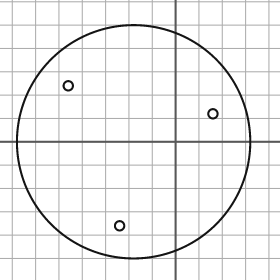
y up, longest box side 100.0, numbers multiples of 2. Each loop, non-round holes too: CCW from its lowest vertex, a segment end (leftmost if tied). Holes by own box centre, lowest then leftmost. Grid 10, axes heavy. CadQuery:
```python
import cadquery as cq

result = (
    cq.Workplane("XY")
    .moveTo(-18.0, 0.0)
    .circle(50.0)
    .moveTo(-24.0, -36.0)
    .circle(2.0)
    .moveTo(16.0, 12.0)
    .circle(2.0)
    .moveTo(-46.0, 24.0)
    .circle(2.0)
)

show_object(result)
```